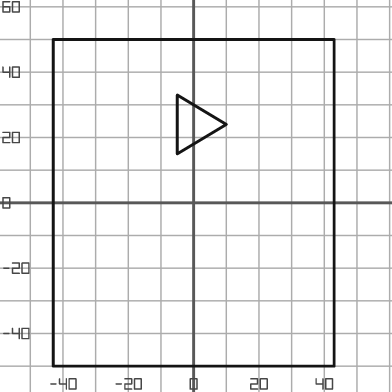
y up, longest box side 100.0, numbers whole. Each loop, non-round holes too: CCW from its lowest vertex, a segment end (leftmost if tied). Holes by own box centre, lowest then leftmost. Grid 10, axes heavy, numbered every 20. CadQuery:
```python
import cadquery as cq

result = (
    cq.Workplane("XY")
    .moveTo(-43.0, -50.0)
    .lineTo(43.0, -50.0)
    .lineTo(43.0, 50.0)
    .lineTo(-43.0, 50.0)
    .close()
    .moveTo(-5.0, 15.0)
    .lineTo(10.0, 24.0)
    .lineTo(-5.0, 33.0)
    .close()
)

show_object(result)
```